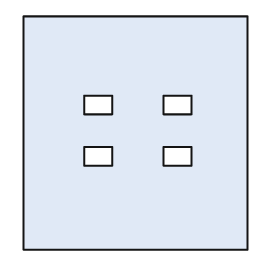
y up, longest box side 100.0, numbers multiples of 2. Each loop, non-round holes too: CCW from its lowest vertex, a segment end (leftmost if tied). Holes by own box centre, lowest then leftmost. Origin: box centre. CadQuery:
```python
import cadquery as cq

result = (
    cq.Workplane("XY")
    .moveTo(-48.0, -50.0)
    .lineTo(48.0, -50.0)
    .lineTo(48.0, 50.0)
    .lineTo(-48.0, 50.0)
    .close()
    .moveTo(-22.0, -14.0)
    .lineTo(-10.0, -14.0)
    .lineTo(-10.0, -6.0)
    .lineTo(-22.0, -6.0)
    .close()
    .moveTo(12.0, -14.0)
    .lineTo(24.0, -14.0)
    .lineTo(24.0, -6.0)
    .lineTo(12.0, -6.0)
    .close()
    .moveTo(-22.0, 8.0)
    .lineTo(-10.0, 8.0)
    .lineTo(-10.0, 16.0)
    .lineTo(-22.0, 16.0)
    .close()
    .moveTo(12.0, 8.0)
    .lineTo(24.0, 8.0)
    .lineTo(24.0, 16.0)
    .lineTo(12.0, 16.0)
    .close()
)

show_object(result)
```